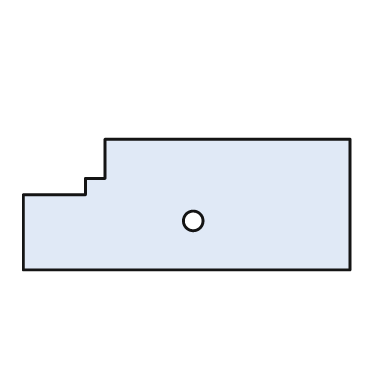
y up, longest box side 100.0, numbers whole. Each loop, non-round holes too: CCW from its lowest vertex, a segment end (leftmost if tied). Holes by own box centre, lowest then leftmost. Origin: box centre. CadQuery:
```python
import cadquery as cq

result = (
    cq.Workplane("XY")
    .moveTo(-50.0, -20.0)
    .lineTo(50.0, -20.0)
    .lineTo(50.0, 20.0)
    .lineTo(-25.0, 20.0)
    .lineTo(-25.0, 8.0)
    .lineTo(-31.0, 8.0)
    .lineTo(-31.0, 3.0)
    .lineTo(-50.0, 3.0)
    .close()
    .moveTo(2.0, -5.0)
    .circle(3.0)
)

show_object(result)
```